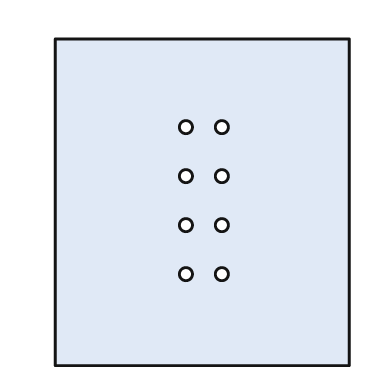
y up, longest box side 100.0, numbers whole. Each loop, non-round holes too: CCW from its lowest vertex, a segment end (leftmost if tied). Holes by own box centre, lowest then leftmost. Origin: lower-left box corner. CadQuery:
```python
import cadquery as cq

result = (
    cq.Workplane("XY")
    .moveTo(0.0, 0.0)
    .lineTo(90.0, 0.0)
    .lineTo(90.0, 100.0)
    .lineTo(0.0, 100.0)
    .close()
    .moveTo(40.0, 28.0)
    .circle(2.0)
    .moveTo(51.0, 28.0)
    .circle(2.0)
    .moveTo(40.0, 43.0)
    .circle(2.0)
    .moveTo(51.0, 43.0)
    .circle(2.0)
    .moveTo(40.0, 58.0)
    .circle(2.0)
    .moveTo(51.0, 58.0)
    .circle(2.0)
    .moveTo(40.0, 73.0)
    .circle(2.0)
    .moveTo(51.0, 73.0)
    .circle(2.0)
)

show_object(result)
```